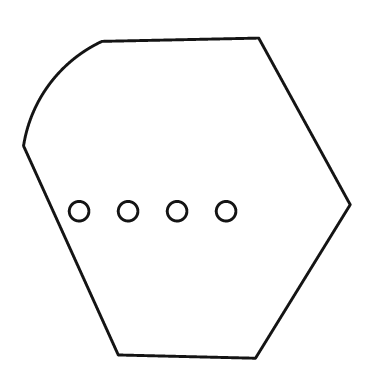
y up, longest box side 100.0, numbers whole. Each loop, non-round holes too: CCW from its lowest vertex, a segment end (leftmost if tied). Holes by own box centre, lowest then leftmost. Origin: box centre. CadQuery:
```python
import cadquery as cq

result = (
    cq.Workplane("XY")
    .moveTo(21.0, -49.0)
    .lineTo(50.0, -2.0)
    .lineTo(22.0, 49.0)
    .lineTo(-26.0, 48.0)
    .threePointArc((-42.0, 35.0), (-50.0, 16.0))
    .lineTo(-21.0, -48.0)
    .close()
    .moveTo(-33.0, -4.0)
    .circle(3.0)
    .moveTo(-18.0, -4.0)
    .circle(3.0)
    .moveTo(-3.0, -4.0)
    .circle(3.0)
    .moveTo(12.0, -4.0)
    .circle(3.0)
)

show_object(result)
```